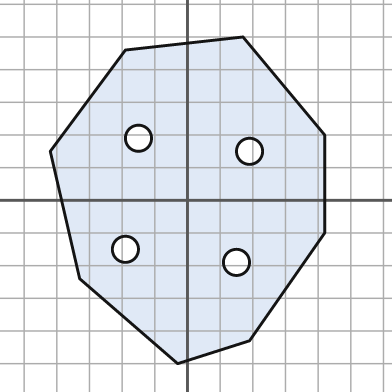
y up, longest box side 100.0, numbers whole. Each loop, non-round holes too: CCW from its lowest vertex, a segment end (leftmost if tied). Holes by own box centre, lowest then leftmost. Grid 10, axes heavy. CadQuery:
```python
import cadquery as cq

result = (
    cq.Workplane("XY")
    .moveTo(-3.0, -50.0)
    .lineTo(19.0, -43.0)
    .lineTo(42.0, -10.0)
    .lineTo(42.0, 20.0)
    .lineTo(17.0, 50.0)
    .lineTo(-19.0, 46.0)
    .lineTo(-42.0, 15.0)
    .lineTo(-33.0, -24.0)
    .close()
    .moveTo(15.0, -19.0)
    .circle(4.0)
    .moveTo(-19.0, -15.0)
    .circle(4.0)
    .moveTo(19.0, 15.0)
    .circle(4.0)
    .moveTo(-15.0, 19.0)
    .circle(4.0)
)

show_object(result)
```